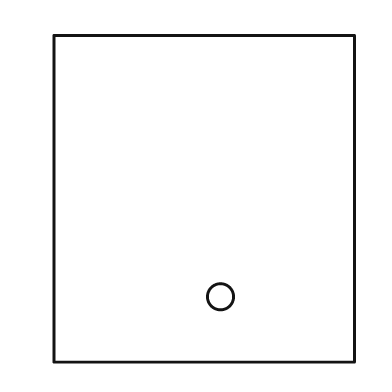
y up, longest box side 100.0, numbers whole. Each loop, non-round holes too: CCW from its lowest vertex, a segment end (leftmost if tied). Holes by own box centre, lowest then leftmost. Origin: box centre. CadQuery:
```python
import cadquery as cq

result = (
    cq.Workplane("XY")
    .moveTo(-46.0, -50.0)
    .lineTo(46.0, -50.0)
    .lineTo(46.0, 50.0)
    .lineTo(-46.0, 50.0)
    .close()
    .moveTo(5.0, -30.0)
    .circle(4.0)
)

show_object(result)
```